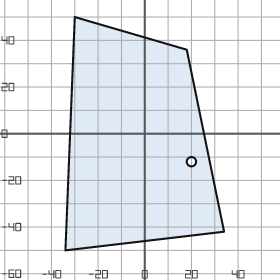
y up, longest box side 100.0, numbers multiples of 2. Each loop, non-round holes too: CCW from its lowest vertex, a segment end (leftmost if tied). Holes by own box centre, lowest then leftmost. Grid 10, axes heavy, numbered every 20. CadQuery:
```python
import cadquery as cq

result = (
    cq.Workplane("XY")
    .moveTo(-34.0, -50.0)
    .lineTo(34.0, -42.0)
    .lineTo(18.0, 36.0)
    .lineTo(-30.0, 50.0)
    .close()
    .moveTo(20.0, -12.0)
    .circle(2.0)
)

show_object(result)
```